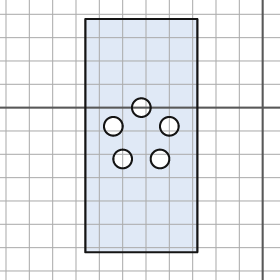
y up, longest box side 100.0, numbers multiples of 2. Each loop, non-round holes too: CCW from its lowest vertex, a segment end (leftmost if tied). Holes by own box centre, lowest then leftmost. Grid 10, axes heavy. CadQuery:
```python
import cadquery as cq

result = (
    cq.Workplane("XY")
    .moveTo(-76.0, -62.0)
    .lineTo(-28.0, -62.0)
    .lineTo(-28.0, 38.0)
    .lineTo(-76.0, 38.0)
    .close()
    .moveTo(-60.0, -22.0)
    .circle(4.0)
    .moveTo(-44.0, -22.0)
    .circle(4.0)
    .moveTo(-64.0, -8.0)
    .circle(4.0)
    .moveTo(-40.0, -8.0)
    .circle(4.0)
    .moveTo(-52.0, 0.0)
    .circle(4.0)
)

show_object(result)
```